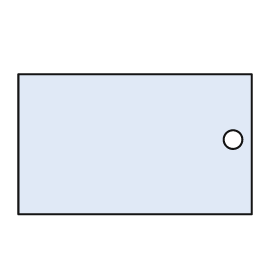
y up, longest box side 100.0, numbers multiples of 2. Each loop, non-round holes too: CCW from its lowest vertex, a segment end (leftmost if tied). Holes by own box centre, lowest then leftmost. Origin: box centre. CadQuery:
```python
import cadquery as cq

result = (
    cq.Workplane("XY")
    .moveTo(-50.0, -30.0)
    .lineTo(50.0, -30.0)
    .lineTo(50.0, 30.0)
    .lineTo(-50.0, 30.0)
    .close()
    .moveTo(42.0, 2.0)
    .circle(4.0)
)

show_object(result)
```